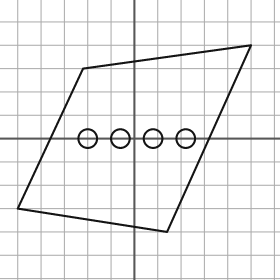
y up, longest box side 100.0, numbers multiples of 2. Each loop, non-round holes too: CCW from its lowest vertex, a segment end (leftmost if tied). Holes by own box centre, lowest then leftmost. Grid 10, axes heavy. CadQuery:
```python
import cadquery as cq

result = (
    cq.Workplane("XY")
    .moveTo(14.0, -40.0)
    .lineTo(50.0, 40.0)
    .lineTo(-22.0, 30.0)
    .lineTo(-50.0, -30.0)
    .close()
    .moveTo(-20.0, 0.0)
    .circle(4.0)
    .moveTo(-6.0, 0.0)
    .circle(4.0)
    .moveTo(8.0, 0.0)
    .circle(4.0)
    .moveTo(22.0, 0.0)
    .circle(4.0)
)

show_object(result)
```